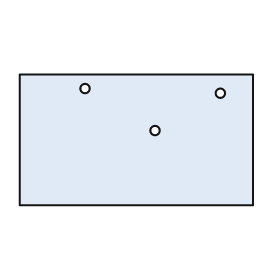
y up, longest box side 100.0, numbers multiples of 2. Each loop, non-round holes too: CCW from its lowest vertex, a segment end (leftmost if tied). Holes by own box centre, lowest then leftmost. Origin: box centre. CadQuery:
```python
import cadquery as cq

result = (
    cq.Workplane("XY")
    .moveTo(-50.0, -28.0)
    .lineTo(50.0, -28.0)
    .lineTo(50.0, 28.0)
    .lineTo(-50.0, 28.0)
    .close()
    .moveTo(8.0, 4.0)
    .circle(2.0)
    .moveTo(36.0, 20.0)
    .circle(2.0)
    .moveTo(-22.0, 22.0)
    .circle(2.0)
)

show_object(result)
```